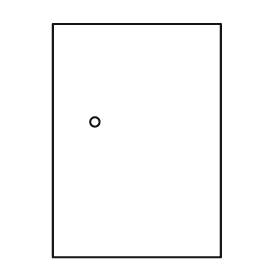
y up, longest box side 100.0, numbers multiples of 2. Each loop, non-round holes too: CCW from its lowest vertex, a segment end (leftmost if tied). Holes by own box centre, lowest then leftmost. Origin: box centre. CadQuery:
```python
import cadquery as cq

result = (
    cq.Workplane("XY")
    .moveTo(-36.0, -50.0)
    .lineTo(36.0, -50.0)
    .lineTo(36.0, 50.0)
    .lineTo(-36.0, 50.0)
    .close()
    .moveTo(-18.0, 8.0)
    .circle(2.0)
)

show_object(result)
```